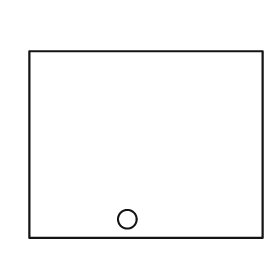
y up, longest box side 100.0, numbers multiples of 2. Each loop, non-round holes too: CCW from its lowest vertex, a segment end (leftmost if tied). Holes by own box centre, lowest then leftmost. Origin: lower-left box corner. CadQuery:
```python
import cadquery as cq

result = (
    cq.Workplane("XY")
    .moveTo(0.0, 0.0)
    .lineTo(100.0, 0.0)
    .lineTo(100.0, 80.0)
    .lineTo(0.0, 80.0)
    .close()
    .moveTo(42.0, 8.0)
    .circle(4.0)
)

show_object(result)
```